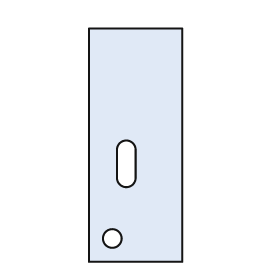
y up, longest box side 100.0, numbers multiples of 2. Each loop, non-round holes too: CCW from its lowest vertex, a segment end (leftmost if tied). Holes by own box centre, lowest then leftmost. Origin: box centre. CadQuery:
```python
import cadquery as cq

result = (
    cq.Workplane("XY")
    .moveTo(-20.0, -50.0)
    .lineTo(20.0, -50.0)
    .lineTo(20.0, 50.0)
    .lineTo(-20.0, 50.0)
    .close()
    .moveTo(-10.0, -40.0)
    .circle(4.0)
    .moveTo(-8.0, -14.0)
    .threePointArc((-4.0, -18.0), (0.0, -14.0))
    .lineTo(0.0, -2.0)
    .threePointArc((-4.0, 2.0), (-8.0, -2.0))
    .close()
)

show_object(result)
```